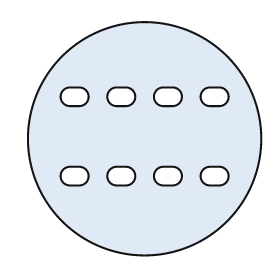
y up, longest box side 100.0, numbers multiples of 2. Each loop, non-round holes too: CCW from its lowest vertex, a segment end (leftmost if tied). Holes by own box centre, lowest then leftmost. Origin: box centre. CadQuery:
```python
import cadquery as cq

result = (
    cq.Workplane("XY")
    .moveTo(0.0, 0.0)
    .circle(50.0)
    .moveTo(-32.0, -20.0)
    .lineTo(-28.0, -20.0)
    .threePointArc((-24.0, -16.0), (-28.0, -12.0))
    .lineTo(-32.0, -12.0)
    .threePointArc((-36.0, -16.0), (-32.0, -20.0))
    .close()
    .moveTo(-12.0, -20.0)
    .lineTo(-8.0, -20.0)
    .threePointArc((-4.0, -16.0), (-8.0, -12.0))
    .lineTo(-12.0, -12.0)
    .threePointArc((-16.0, -16.0), (-12.0, -20.0))
    .close()
    .moveTo(8.0, -20.0)
    .lineTo(12.0, -20.0)
    .threePointArc((16.0, -16.0), (12.0, -12.0))
    .lineTo(8.0, -12.0)
    .threePointArc((4.0, -16.0), (8.0, -20.0))
    .close()
    .moveTo(28.0, -20.0)
    .lineTo(32.0, -20.0)
    .threePointArc((36.0, -16.0), (32.0, -12.0))
    .lineTo(28.0, -12.0)
    .threePointArc((24.0, -16.0), (28.0, -20.0))
    .close()
    .moveTo(-32.0, 14.0)
    .lineTo(-28.0, 14.0)
    .threePointArc((-24.0, 18.0), (-28.0, 22.0))
    .lineTo(-32.0, 22.0)
    .threePointArc((-36.0, 18.0), (-32.0, 14.0))
    .close()
    .moveTo(-12.0, 14.0)
    .lineTo(-8.0, 14.0)
    .threePointArc((-4.0, 18.0), (-8.0, 22.0))
    .lineTo(-12.0, 22.0)
    .threePointArc((-16.0, 18.0), (-12.0, 14.0))
    .close()
    .moveTo(8.0, 14.0)
    .lineTo(12.0, 14.0)
    .threePointArc((16.0, 18.0), (12.0, 22.0))
    .lineTo(8.0, 22.0)
    .threePointArc((4.0, 18.0), (8.0, 14.0))
    .close()
    .moveTo(28.0, 14.0)
    .lineTo(32.0, 14.0)
    .threePointArc((36.0, 18.0), (32.0, 22.0))
    .lineTo(28.0, 22.0)
    .threePointArc((24.0, 18.0), (28.0, 14.0))
    .close()
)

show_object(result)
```